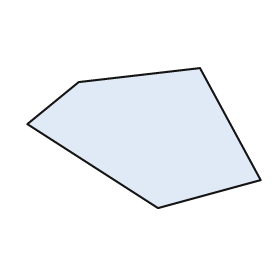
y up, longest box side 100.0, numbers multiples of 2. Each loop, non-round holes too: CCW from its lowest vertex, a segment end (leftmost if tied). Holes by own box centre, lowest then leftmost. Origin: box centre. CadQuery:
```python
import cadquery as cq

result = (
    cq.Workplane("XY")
    .moveTo(6.0, -30.0)
    .lineTo(50.0, -18.0)
    .lineTo(24.0, 30.0)
    .lineTo(-28.0, 24.0)
    .lineTo(-50.0, 6.0)
    .close()
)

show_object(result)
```